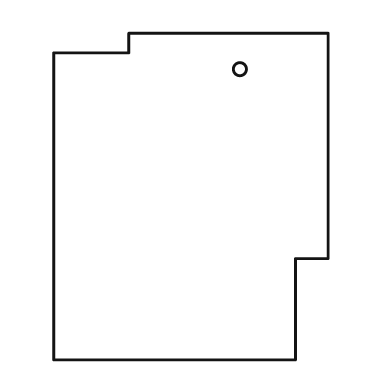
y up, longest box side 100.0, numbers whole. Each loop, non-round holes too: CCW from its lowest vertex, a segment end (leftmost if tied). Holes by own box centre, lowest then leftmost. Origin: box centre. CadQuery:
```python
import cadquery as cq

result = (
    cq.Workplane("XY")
    .moveTo(-42.0, -50.0)
    .lineTo(32.0, -50.0)
    .lineTo(32.0, -19.0)
    .lineTo(42.0, -19.0)
    .lineTo(42.0, 50.0)
    .lineTo(-19.0, 50.0)
    .lineTo(-19.0, 44.0)
    .lineTo(-42.0, 44.0)
    .close()
    .moveTo(15.0, 39.0)
    .circle(2.0)
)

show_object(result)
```